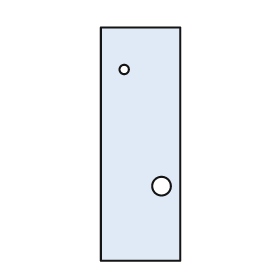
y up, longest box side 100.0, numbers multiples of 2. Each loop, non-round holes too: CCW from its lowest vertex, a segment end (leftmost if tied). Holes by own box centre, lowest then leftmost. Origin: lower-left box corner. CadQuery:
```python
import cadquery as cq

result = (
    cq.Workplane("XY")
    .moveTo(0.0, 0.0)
    .lineTo(34.0, 0.0)
    .lineTo(34.0, 100.0)
    .lineTo(0.0, 100.0)
    .close()
    .moveTo(26.0, 32.0)
    .circle(4.0)
    .moveTo(10.0, 82.0)
    .circle(2.0)
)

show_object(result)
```